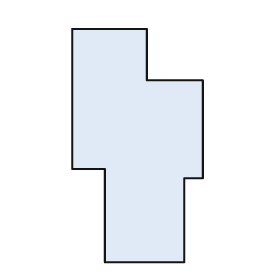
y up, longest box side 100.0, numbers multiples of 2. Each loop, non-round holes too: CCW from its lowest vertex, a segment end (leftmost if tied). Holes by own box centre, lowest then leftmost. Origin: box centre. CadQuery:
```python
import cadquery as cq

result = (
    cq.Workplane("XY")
    .moveTo(-14.0, -50.0)
    .lineTo(20.0, -50.0)
    .lineTo(20.0, -14.0)
    .lineTo(28.0, -14.0)
    .lineTo(28.0, 28.0)
    .lineTo(4.0, 28.0)
    .lineTo(4.0, 50.0)
    .lineTo(-28.0, 50.0)
    .lineTo(-28.0, -10.0)
    .lineTo(-14.0, -10.0)
    .close()
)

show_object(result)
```